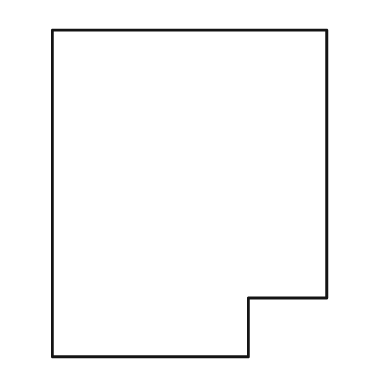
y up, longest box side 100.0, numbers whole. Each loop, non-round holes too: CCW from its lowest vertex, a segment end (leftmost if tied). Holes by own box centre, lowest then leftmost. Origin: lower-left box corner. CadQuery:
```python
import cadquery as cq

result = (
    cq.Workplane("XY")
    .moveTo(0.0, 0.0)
    .lineTo(60.0, 0.0)
    .lineTo(60.0, 18.0)
    .lineTo(84.0, 18.0)
    .lineTo(84.0, 100.0)
    .lineTo(0.0, 100.0)
    .close()
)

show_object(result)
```